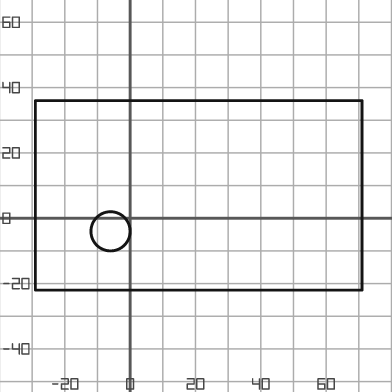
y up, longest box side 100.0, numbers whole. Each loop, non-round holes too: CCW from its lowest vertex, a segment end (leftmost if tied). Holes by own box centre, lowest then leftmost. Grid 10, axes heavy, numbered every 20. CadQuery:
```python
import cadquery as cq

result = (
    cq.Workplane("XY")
    .moveTo(-29.0, -22.0)
    .lineTo(71.0, -22.0)
    .lineTo(71.0, 36.0)
    .lineTo(-29.0, 36.0)
    .close()
    .moveTo(-6.0, -4.0)
    .circle(6.0)
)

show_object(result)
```